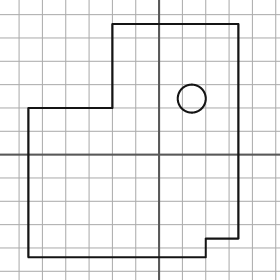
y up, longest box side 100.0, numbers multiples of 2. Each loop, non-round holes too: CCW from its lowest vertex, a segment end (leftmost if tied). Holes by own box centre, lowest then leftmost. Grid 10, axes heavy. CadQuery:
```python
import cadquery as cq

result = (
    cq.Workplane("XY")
    .moveTo(-56.0, -44.0)
    .lineTo(20.0, -44.0)
    .lineTo(20.0, -36.0)
    .lineTo(34.0, -36.0)
    .lineTo(34.0, 56.0)
    .lineTo(-20.0, 56.0)
    .lineTo(-20.0, 20.0)
    .lineTo(-56.0, 20.0)
    .close()
    .moveTo(14.0, 24.0)
    .circle(6.0)
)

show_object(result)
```